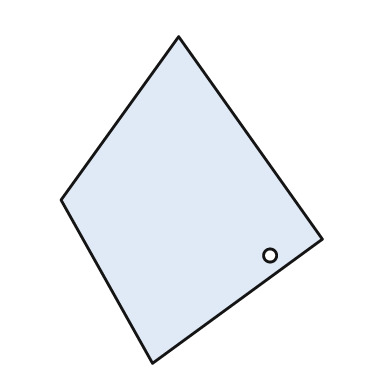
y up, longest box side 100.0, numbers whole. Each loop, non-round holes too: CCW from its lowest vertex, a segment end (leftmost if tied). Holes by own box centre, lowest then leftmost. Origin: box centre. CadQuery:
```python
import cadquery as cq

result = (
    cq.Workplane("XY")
    .moveTo(-12.0, -50.0)
    .lineTo(40.0, -12.0)
    .lineTo(-4.0, 50.0)
    .lineTo(-40.0, 0.0)
    .close()
    .moveTo(24.0, -17.0)
    .circle(2.0)
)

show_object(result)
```